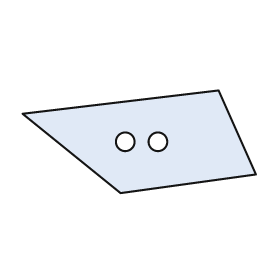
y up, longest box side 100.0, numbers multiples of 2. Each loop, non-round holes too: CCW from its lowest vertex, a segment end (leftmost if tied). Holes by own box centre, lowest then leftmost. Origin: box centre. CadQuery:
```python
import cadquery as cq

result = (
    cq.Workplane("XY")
    .moveTo(-8.0, -22.0)
    .lineTo(50.0, -14.0)
    .lineTo(34.0, 22.0)
    .lineTo(-50.0, 12.0)
    .close()
    .moveTo(-6.0, 0.0)
    .circle(4.0)
    .moveTo(8.0, 0.0)
    .circle(4.0)
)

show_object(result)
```